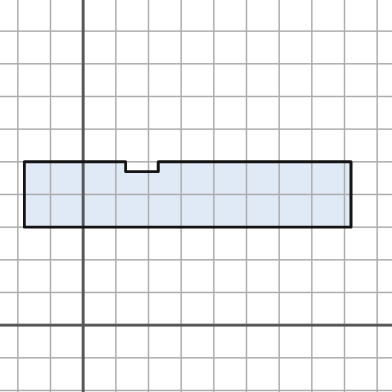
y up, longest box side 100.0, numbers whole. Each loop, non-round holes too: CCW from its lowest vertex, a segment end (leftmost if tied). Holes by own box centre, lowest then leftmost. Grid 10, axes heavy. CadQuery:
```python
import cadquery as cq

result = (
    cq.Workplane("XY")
    .moveTo(-18.0, 30.0)
    .lineTo(82.0, 30.0)
    .lineTo(82.0, 50.0)
    .lineTo(23.0, 50.0)
    .lineTo(23.0, 47.0)
    .lineTo(13.0, 47.0)
    .lineTo(13.0, 50.0)
    .lineTo(-18.0, 50.0)
    .close()
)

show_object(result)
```